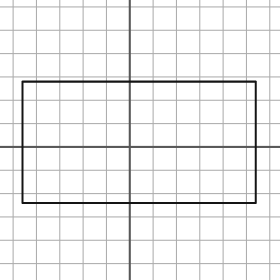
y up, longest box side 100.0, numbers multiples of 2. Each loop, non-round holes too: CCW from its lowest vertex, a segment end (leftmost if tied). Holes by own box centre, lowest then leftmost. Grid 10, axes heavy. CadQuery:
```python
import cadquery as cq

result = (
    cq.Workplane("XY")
    .moveTo(-46.0, -24.0)
    .lineTo(54.0, -24.0)
    .lineTo(54.0, 28.0)
    .lineTo(-46.0, 28.0)
    .close()
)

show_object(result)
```